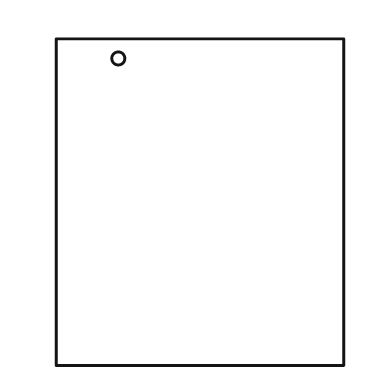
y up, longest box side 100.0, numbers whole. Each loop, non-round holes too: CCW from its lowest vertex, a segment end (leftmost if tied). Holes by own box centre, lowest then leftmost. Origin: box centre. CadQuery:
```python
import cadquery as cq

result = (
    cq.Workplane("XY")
    .moveTo(-44.0, -50.0)
    .lineTo(44.0, -50.0)
    .lineTo(44.0, 50.0)
    .lineTo(-44.0, 50.0)
    .close()
    .moveTo(-25.0, 44.0)
    .circle(2.0)
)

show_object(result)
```